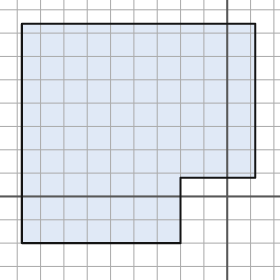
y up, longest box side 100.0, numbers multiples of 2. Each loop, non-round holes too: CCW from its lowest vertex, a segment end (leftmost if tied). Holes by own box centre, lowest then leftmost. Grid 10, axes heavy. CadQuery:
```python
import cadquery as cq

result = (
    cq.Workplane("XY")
    .moveTo(-88.0, -20.0)
    .lineTo(-20.0, -20.0)
    .lineTo(-20.0, 8.0)
    .lineTo(12.0, 8.0)
    .lineTo(12.0, 74.0)
    .lineTo(-88.0, 74.0)
    .close()
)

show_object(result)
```